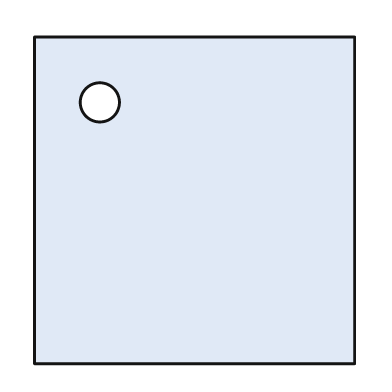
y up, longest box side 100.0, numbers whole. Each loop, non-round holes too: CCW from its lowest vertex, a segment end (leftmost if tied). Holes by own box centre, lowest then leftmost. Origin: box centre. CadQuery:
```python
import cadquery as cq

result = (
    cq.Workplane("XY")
    .moveTo(-49.0, -50.0)
    .lineTo(49.0, -50.0)
    .lineTo(49.0, 50.0)
    .lineTo(-49.0, 50.0)
    .close()
    .moveTo(-29.0, 30.0)
    .circle(6.0)
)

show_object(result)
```